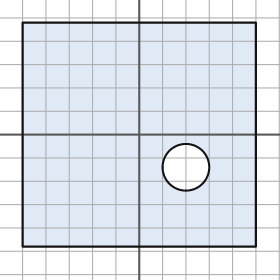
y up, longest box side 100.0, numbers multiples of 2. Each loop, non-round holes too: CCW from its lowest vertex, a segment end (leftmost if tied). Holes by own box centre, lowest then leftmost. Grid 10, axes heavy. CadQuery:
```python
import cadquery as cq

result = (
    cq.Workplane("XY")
    .moveTo(-50.0, -48.0)
    .lineTo(50.0, -48.0)
    .lineTo(50.0, 48.0)
    .lineTo(-50.0, 48.0)
    .close()
    .moveTo(20.0, -14.0)
    .circle(10.0)
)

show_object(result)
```